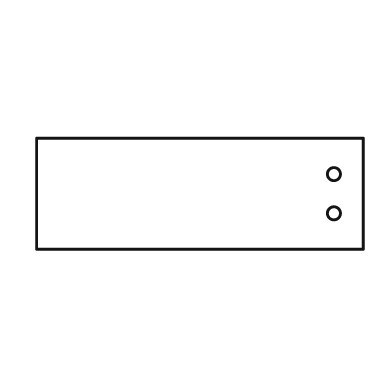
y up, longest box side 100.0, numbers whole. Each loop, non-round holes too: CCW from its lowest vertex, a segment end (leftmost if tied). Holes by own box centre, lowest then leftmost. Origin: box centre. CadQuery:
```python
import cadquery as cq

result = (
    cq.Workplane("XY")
    .moveTo(-50.0, -17.0)
    .lineTo(50.0, -17.0)
    .lineTo(50.0, 17.0)
    .lineTo(-50.0, 17.0)
    .close()
    .moveTo(41.0, -6.0)
    .circle(2.0)
    .moveTo(41.0, 6.0)
    .circle(2.0)
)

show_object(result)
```